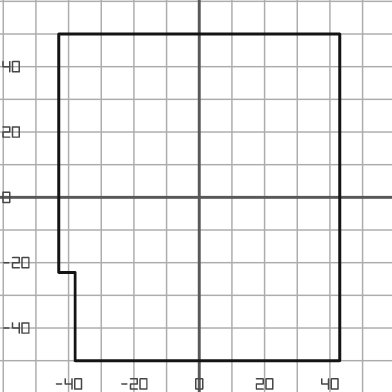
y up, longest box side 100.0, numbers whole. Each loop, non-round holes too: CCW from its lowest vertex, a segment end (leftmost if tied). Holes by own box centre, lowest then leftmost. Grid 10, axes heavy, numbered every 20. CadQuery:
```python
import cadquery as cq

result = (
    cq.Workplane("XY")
    .moveTo(-38.0, -50.0)
    .lineTo(43.0, -50.0)
    .lineTo(43.0, 50.0)
    .lineTo(-43.0, 50.0)
    .lineTo(-43.0, -23.0)
    .lineTo(-38.0, -23.0)
    .close()
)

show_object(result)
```